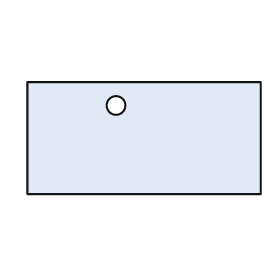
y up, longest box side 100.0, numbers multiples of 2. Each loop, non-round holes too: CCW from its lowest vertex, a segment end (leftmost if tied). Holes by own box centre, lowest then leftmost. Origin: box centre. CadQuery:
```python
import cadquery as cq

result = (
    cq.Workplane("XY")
    .moveTo(-50.0, -24.0)
    .lineTo(50.0, -24.0)
    .lineTo(50.0, 24.0)
    .lineTo(-50.0, 24.0)
    .close()
    .moveTo(-12.0, 14.0)
    .circle(4.0)
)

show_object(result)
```